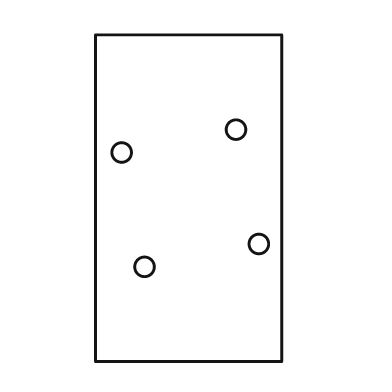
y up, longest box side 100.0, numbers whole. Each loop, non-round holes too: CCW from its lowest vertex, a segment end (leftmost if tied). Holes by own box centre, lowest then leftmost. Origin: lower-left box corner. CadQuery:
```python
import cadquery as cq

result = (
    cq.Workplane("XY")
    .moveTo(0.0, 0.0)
    .lineTo(57.0, 0.0)
    .lineTo(57.0, 100.0)
    .lineTo(0.0, 100.0)
    .close()
    .moveTo(15.0, 29.0)
    .circle(3.0)
    .moveTo(50.0, 36.0)
    .circle(3.0)
    .moveTo(8.0, 64.0)
    .circle(3.0)
    .moveTo(43.0, 71.0)
    .circle(3.0)
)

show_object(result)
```